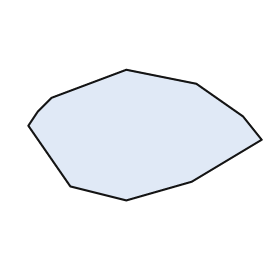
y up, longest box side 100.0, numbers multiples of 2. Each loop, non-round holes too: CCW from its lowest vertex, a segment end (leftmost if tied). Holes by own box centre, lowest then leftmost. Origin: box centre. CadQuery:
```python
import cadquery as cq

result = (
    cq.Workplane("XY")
    .moveTo(-8.0, -28.0)
    .lineTo(20.0, -20.0)
    .lineTo(50.0, -2.0)
    .lineTo(42.0, 8.0)
    .lineTo(22.0, 22.0)
    .lineTo(-8.0, 28.0)
    .lineTo(-40.0, 16.0)
    .lineTo(-46.0, 10.0)
    .lineTo(-50.0, 4.0)
    .lineTo(-32.0, -22.0)
    .close()
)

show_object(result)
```